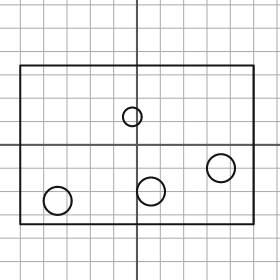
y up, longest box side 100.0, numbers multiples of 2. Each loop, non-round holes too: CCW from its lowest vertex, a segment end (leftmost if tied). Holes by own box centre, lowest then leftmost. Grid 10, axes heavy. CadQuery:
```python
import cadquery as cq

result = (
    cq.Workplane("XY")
    .moveTo(-50.0, -34.0)
    .lineTo(50.0, -34.0)
    .lineTo(50.0, 34.0)
    .lineTo(-50.0, 34.0)
    .close()
    .moveTo(-34.0, -24.0)
    .circle(6.0)
    .moveTo(6.0, -20.0)
    .circle(6.0)
    .moveTo(36.0, -10.0)
    .circle(6.0)
    .moveTo(-2.0, 12.0)
    .circle(4.0)
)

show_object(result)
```